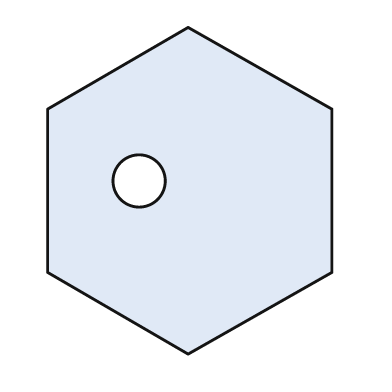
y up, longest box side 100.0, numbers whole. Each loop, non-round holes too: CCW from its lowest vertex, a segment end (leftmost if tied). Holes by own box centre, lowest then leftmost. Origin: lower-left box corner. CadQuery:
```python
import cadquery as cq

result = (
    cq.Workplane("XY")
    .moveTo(43.0, 0.0)
    .lineTo(87.0, 25.0)
    .lineTo(87.0, 75.0)
    .lineTo(43.0, 100.0)
    .lineTo(0.0, 75.0)
    .lineTo(0.0, 25.0)
    .close()
    .moveTo(28.0, 53.0)
    .circle(8.0)
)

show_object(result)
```